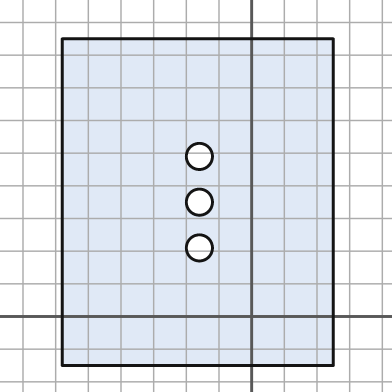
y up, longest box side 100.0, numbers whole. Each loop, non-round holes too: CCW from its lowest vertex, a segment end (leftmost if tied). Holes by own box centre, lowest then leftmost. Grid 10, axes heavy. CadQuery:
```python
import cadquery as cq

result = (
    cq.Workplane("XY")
    .moveTo(-58.0, -15.0)
    .lineTo(25.0, -15.0)
    .lineTo(25.0, 85.0)
    .lineTo(-58.0, 85.0)
    .close()
    .moveTo(-16.0, 21.0)
    .circle(4.0)
    .moveTo(-16.0, 35.0)
    .circle(4.0)
    .moveTo(-16.0, 49.0)
    .circle(4.0)
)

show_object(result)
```